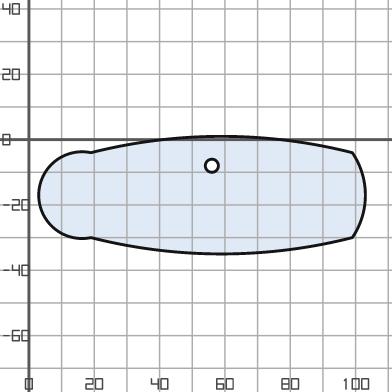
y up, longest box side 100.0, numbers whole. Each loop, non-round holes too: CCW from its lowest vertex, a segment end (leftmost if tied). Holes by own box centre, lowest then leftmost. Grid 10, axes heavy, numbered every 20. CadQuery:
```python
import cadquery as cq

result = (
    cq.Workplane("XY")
    .moveTo(19.0, -30.0)
    .threePointArc((59.0, -35.0), (99.0, -30.0))
    .threePointArc((103.0, -17.0), (99.0, -4.0))
    .threePointArc((59.0, 1.0), (19.0, -4.0))
    .threePointArc((3.0, -17.0), (19.0, -30.0))
    .close()
    .moveTo(56.0, -8.0)
    .circle(2.0)
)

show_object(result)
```